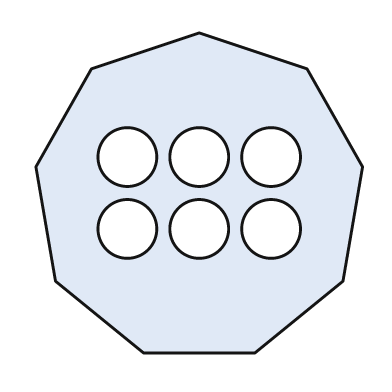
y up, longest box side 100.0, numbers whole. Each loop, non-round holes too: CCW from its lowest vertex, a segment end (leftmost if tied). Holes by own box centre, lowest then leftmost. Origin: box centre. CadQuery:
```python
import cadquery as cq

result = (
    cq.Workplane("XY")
    .moveTo(-17.0, -49.0)
    .lineTo(17.0, -49.0)
    .lineTo(44.0, -27.0)
    .lineTo(50.0, 8.0)
    .lineTo(33.0, 38.0)
    .lineTo(0.0, 49.0)
    .lineTo(-33.0, 38.0)
    .lineTo(-50.0, 8.0)
    .lineTo(-44.0, -27.0)
    .close()
    .moveTo(-22.0, -11.0)
    .circle(9.0)
    .moveTo(0.0, -11.0)
    .circle(9.0)
    .moveTo(22.0, -11.0)
    .circle(9.0)
    .moveTo(-22.0, 11.0)
    .circle(9.0)
    .moveTo(0.0, 11.0)
    .circle(9.0)
    .moveTo(22.0, 11.0)
    .circle(9.0)
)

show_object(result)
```